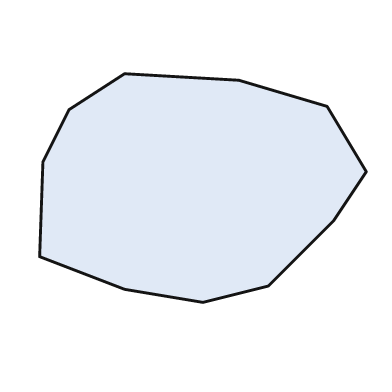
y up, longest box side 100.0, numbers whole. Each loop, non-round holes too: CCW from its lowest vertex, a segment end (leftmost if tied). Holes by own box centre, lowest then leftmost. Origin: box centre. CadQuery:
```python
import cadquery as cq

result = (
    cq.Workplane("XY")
    .moveTo(0.0, -35.0)
    .lineTo(20.0, -30.0)
    .lineTo(40.0, -10.0)
    .lineTo(50.0, 5.0)
    .lineTo(38.0, 25.0)
    .lineTo(11.0, 33.0)
    .lineTo(-24.0, 35.0)
    .lineTo(-41.0, 24.0)
    .lineTo(-49.0, 8.0)
    .lineTo(-50.0, -21.0)
    .lineTo(-24.0, -31.0)
    .close()
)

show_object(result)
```